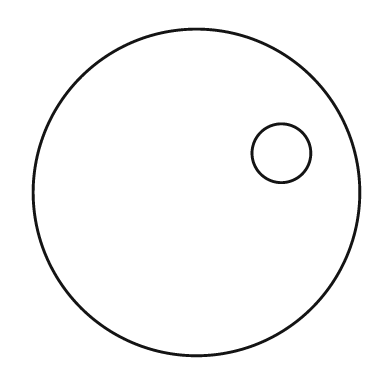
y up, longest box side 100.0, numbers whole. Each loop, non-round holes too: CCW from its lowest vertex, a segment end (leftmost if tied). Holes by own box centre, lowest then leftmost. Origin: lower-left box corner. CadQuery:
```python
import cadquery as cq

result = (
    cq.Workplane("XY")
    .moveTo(50.0, 50.0)
    .circle(50.0)
    .moveTo(76.0, 62.0)
    .circle(9.0)
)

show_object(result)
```